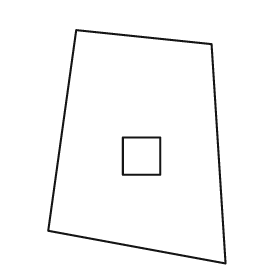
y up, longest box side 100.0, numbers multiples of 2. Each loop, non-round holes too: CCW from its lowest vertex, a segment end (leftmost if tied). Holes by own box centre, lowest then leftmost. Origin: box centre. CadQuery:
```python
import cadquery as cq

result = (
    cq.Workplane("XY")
    .moveTo(38.0, -50.0)
    .lineTo(32.0, 44.0)
    .lineTo(-26.0, 50.0)
    .lineTo(-38.0, -36.0)
    .close()
    .moveTo(-6.0, -12.0)
    .lineTo(10.0, -12.0)
    .lineTo(10.0, 4.0)
    .lineTo(-6.0, 4.0)
    .close()
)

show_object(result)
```